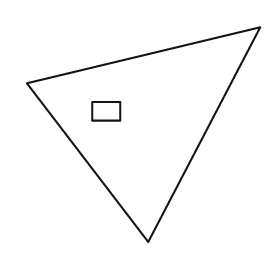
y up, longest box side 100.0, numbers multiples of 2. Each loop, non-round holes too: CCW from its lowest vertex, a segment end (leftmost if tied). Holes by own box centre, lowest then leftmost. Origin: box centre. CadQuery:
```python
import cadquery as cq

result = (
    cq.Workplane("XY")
    .moveTo(2.0, -46.0)
    .lineTo(50.0, 46.0)
    .lineTo(-50.0, 22.0)
    .close()
    .moveTo(-22.0, 6.0)
    .lineTo(-10.0, 6.0)
    .lineTo(-10.0, 14.0)
    .lineTo(-22.0, 14.0)
    .close()
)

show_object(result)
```